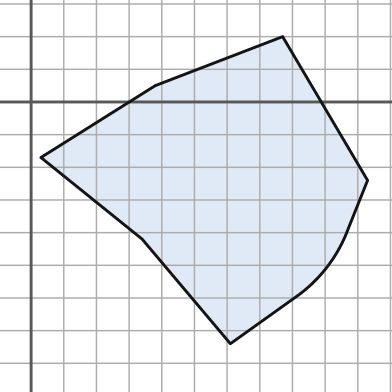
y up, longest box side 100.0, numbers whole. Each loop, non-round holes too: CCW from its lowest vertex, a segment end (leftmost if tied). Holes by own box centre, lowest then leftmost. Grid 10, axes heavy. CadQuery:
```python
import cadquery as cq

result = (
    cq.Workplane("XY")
    .moveTo(61.0, -74.0)
    .lineTo(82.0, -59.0)
    .threePointArc((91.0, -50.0), (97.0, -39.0))
    .lineTo(103.0, -24.0)
    .lineTo(77.0, 20.0)
    .lineTo(38.0, 5.0)
    .lineTo(3.0, -17.0)
    .lineTo(34.0, -42.0)
    .close()
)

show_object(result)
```